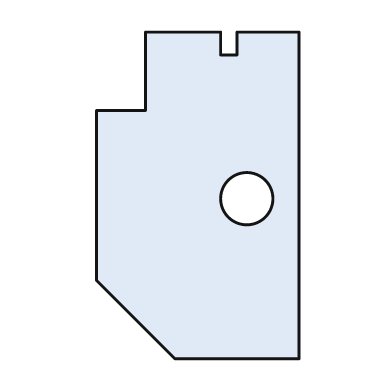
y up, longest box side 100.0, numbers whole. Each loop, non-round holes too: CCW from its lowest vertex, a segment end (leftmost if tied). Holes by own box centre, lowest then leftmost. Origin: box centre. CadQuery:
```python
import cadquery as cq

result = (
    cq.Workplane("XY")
    .moveTo(-7.0, -50.0)
    .lineTo(31.0, -50.0)
    .lineTo(31.0, 50.0)
    .lineTo(12.0, 50.0)
    .lineTo(12.0, 43.0)
    .lineTo(7.0, 43.0)
    .lineTo(7.0, 50.0)
    .lineTo(-16.0, 50.0)
    .lineTo(-16.0, 26.0)
    .lineTo(-31.0, 26.0)
    .lineTo(-31.0, -26.0)
    .close()
    .moveTo(15.0, -1.0)
    .circle(8.0)
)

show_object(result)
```